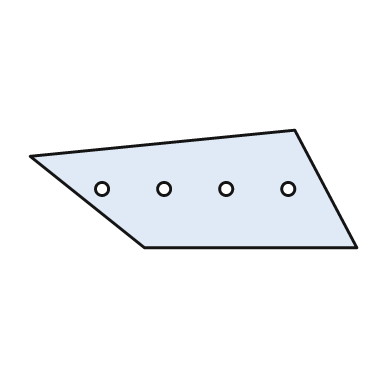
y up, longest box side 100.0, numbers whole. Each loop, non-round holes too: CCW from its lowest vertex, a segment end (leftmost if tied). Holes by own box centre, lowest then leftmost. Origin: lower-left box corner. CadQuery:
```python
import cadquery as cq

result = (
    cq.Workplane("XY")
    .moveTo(35.0, 0.0)
    .lineTo(100.0, 0.0)
    .lineTo(81.0, 36.0)
    .lineTo(0.0, 28.0)
    .close()
    .moveTo(22.0, 18.0)
    .circle(2.0)
    .moveTo(41.0, 18.0)
    .circle(2.0)
    .moveTo(60.0, 18.0)
    .circle(2.0)
    .moveTo(79.0, 18.0)
    .circle(2.0)
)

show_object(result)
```